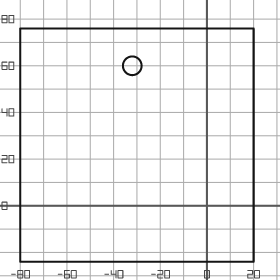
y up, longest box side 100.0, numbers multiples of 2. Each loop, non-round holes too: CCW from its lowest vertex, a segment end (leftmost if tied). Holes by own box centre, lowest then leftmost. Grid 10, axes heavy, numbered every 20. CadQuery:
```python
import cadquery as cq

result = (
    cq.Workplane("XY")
    .moveTo(-80.0, -24.0)
    .lineTo(20.0, -24.0)
    .lineTo(20.0, 76.0)
    .lineTo(-80.0, 76.0)
    .close()
    .moveTo(-32.0, 60.0)
    .circle(4.0)
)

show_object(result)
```